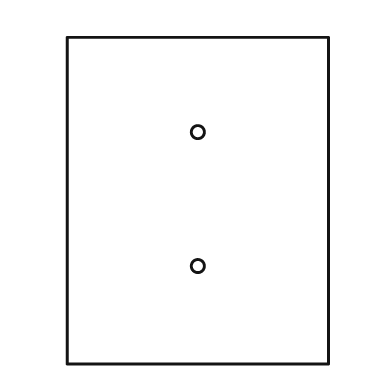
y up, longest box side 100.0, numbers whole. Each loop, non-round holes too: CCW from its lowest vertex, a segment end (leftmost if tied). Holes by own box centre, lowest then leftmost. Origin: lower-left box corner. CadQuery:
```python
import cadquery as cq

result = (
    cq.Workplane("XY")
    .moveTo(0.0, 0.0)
    .lineTo(80.0, 0.0)
    .lineTo(80.0, 100.0)
    .lineTo(0.0, 100.0)
    .close()
    .moveTo(40.0, 30.0)
    .circle(2.0)
    .moveTo(40.0, 71.0)
    .circle(2.0)
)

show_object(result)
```